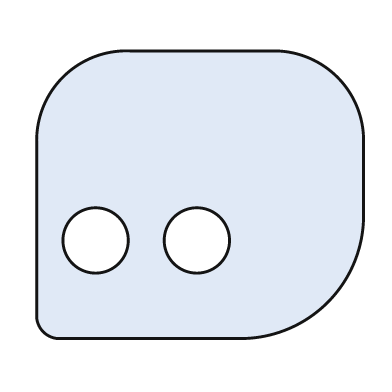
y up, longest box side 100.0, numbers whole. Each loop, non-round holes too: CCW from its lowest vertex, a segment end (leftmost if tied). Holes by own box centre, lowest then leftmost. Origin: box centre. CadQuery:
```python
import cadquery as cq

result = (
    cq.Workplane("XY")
    .moveTo(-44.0, -44.0)
    .lineTo(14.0, -44.0)
    .threePointArc((39.0, -33.0), (50.0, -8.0))
    .lineTo(50.0, 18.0)
    .threePointArc((42.0, 36.0), (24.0, 44.0))
    .lineTo(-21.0, 44.0)
    .threePointArc((-42.0, 36.0), (-50.0, 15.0))
    .lineTo(-50.0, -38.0)
    .threePointArc((-48.0, -42.0), (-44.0, -44.0))
    .close()
    .moveTo(-32.0, -14.0)
    .circle(10.0)
    .moveTo(-1.0, -14.0)
    .circle(10.0)
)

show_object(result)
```